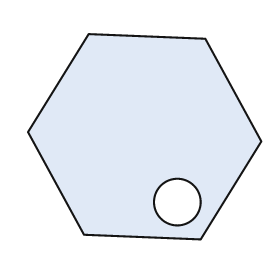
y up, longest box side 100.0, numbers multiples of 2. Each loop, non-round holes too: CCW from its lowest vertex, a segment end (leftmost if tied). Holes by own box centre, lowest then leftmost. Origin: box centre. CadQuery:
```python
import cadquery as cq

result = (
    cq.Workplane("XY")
    .moveTo(24.0, -44.0)
    .lineTo(50.0, -2.0)
    .lineTo(26.0, 42.0)
    .lineTo(-24.0, 44.0)
    .lineTo(-50.0, 2.0)
    .lineTo(-26.0, -42.0)
    .close()
    .moveTo(14.0, -28.0)
    .circle(10.0)
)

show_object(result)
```